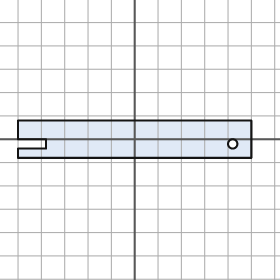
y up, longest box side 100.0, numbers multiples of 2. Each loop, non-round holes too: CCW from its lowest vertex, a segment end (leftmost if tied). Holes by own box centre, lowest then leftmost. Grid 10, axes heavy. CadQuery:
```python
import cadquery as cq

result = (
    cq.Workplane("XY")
    .moveTo(-50.0, -8.0)
    .lineTo(50.0, -8.0)
    .lineTo(50.0, 8.0)
    .lineTo(-50.0, 8.0)
    .lineTo(-50.0, 0.0)
    .lineTo(-38.0, 0.0)
    .lineTo(-38.0, -4.0)
    .lineTo(-50.0, -4.0)
    .close()
    .moveTo(42.0, -2.0)
    .circle(2.0)
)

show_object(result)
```